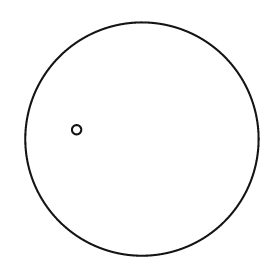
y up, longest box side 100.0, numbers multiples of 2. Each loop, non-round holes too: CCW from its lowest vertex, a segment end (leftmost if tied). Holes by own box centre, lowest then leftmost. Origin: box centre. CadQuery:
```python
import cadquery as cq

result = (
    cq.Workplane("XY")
    .moveTo(0.0, 0.0)
    .circle(50.0)
    .moveTo(-28.0, 4.0)
    .circle(2.0)
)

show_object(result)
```